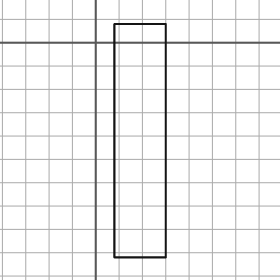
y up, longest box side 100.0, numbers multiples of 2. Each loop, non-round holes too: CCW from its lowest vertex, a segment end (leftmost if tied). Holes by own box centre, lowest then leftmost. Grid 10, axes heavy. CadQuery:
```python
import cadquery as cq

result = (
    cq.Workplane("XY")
    .moveTo(8.0, -92.0)
    .lineTo(30.0, -92.0)
    .lineTo(30.0, 8.0)
    .lineTo(8.0, 8.0)
    .close()
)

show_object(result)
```